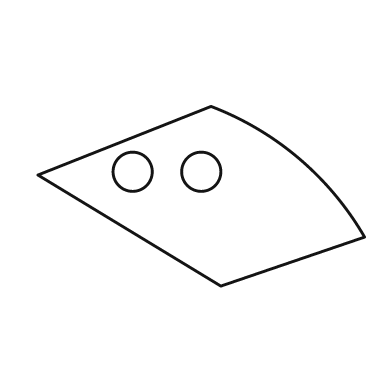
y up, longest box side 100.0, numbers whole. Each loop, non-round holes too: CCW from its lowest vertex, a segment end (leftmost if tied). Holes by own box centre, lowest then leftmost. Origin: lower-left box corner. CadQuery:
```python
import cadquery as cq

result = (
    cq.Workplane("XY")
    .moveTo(56.0, 0.0)
    .lineTo(100.0, 15.0)
    .threePointArc((80.0, 39.0), (53.0, 55.0))
    .lineTo(0.0, 34.0)
    .close()
    .moveTo(29.0, 35.0)
    .circle(6.0)
    .moveTo(50.0, 35.0)
    .circle(6.0)
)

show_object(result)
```